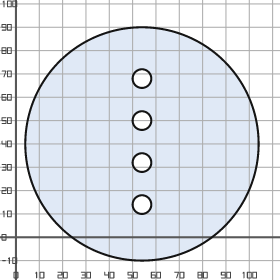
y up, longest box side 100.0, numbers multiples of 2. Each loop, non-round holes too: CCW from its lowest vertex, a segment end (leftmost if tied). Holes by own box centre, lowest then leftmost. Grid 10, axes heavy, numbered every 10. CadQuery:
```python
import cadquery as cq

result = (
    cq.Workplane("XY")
    .moveTo(54.0, 40.0)
    .circle(50.0)
    .moveTo(54.0, 14.0)
    .circle(4.0)
    .moveTo(54.0, 32.0)
    .circle(4.0)
    .moveTo(54.0, 50.0)
    .circle(4.0)
    .moveTo(54.0, 68.0)
    .circle(4.0)
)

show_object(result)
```